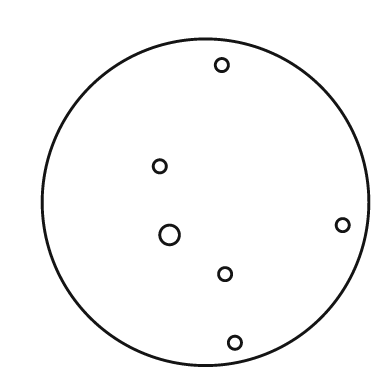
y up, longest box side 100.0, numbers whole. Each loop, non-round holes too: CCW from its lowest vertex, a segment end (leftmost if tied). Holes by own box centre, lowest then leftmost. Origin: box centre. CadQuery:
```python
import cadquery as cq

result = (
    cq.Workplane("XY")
    .moveTo(0.0, 0.0)
    .circle(50.0)
    .moveTo(9.0, -43.0)
    .circle(2.0)
    .moveTo(6.0, -22.0)
    .circle(2.0)
    .moveTo(-11.0, -10.0)
    .circle(3.0)
    .moveTo(42.0, -7.0)
    .circle(2.0)
    .moveTo(-14.0, 11.0)
    .circle(2.0)
    .moveTo(5.0, 42.0)
    .circle(2.0)
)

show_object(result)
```